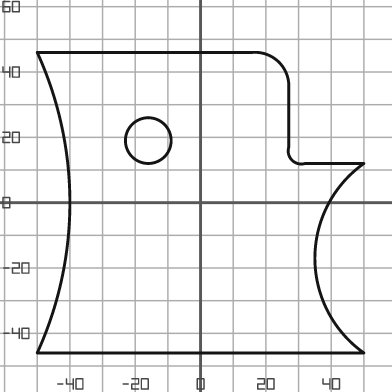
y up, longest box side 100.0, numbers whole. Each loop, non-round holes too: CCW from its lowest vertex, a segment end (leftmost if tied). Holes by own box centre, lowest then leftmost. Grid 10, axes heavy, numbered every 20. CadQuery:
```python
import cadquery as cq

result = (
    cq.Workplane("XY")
    .moveTo(-50.0, -46.0)
    .lineTo(50.0, -46.0)
    .threePointArc((35.0, -17.0), (50.0, 12.0))
    .lineTo(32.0, 12.0)
    .threePointArc((28.0, 13.0), (27.0, 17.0))
    .lineTo(27.0, 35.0)
    .threePointArc((24.0, 43.0), (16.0, 46.0))
    .lineTo(-50.0, 46.0)
    .threePointArc((-40.0, 0.0), (-50.0, -46.0))
    .close()
    .moveTo(-16.0, 19.0)
    .circle(7.0)
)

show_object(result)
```